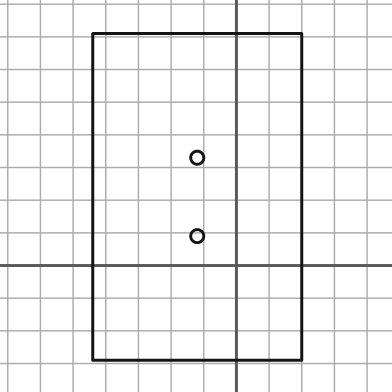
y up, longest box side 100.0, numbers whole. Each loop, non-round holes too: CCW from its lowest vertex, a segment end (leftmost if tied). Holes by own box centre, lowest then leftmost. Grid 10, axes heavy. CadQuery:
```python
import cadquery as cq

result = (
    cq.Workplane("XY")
    .moveTo(-44.0, -29.0)
    .lineTo(20.0, -29.0)
    .lineTo(20.0, 71.0)
    .lineTo(-44.0, 71.0)
    .close()
    .moveTo(-12.0, 9.0)
    .circle(2.0)
    .moveTo(-12.0, 33.0)
    .circle(2.0)
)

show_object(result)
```